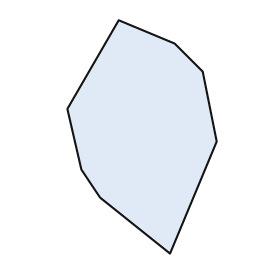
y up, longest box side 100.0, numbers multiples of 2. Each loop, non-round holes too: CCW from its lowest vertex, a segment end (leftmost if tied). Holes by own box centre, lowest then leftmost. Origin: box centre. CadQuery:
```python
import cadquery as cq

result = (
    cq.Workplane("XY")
    .moveTo(12.0, -50.0)
    .lineTo(32.0, -2.0)
    .lineTo(26.0, 28.0)
    .lineTo(14.0, 40.0)
    .lineTo(-10.0, 50.0)
    .lineTo(-32.0, 12.0)
    .lineTo(-26.0, -14.0)
    .lineTo(-18.0, -26.0)
    .close()
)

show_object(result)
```